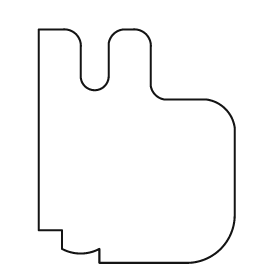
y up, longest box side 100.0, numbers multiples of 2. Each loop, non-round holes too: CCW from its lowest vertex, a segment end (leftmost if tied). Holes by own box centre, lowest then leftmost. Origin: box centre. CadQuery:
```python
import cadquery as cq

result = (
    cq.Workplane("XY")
    .moveTo(-16.0, -50.0)
    .lineTo(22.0, -50.0)
    .threePointArc((36.0, -44.0), (42.0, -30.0))
    .lineTo(42.0, 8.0)
    .threePointArc((38.0, 16.0), (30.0, 20.0))
    .lineTo(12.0, 20.0)
    .threePointArc((8.0, 22.0), (6.0, 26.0))
    .lineTo(6.0, 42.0)
    .threePointArc((4.0, 48.0), (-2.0, 50.0))
    .lineTo(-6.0, 50.0)
    .threePointArc((-10.0, 48.0), (-12.0, 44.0))
    .lineTo(-12.0, 30.0)
    .threePointArc((-18.0, 24.0), (-24.0, 30.0))
    .lineTo(-24.0, 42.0)
    .threePointArc((-26.0, 48.0), (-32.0, 50.0))
    .lineTo(-42.0, 50.0)
    .lineTo(-42.0, -36.0)
    .lineTo(-32.0, -36.0)
    .lineTo(-32.0, -44.0)
    .threePointArc((-24.0, -46.0), (-16.0, -44.0))
    .close()
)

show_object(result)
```